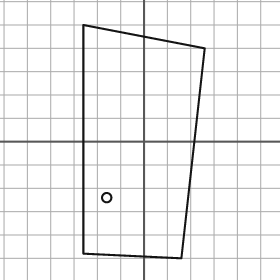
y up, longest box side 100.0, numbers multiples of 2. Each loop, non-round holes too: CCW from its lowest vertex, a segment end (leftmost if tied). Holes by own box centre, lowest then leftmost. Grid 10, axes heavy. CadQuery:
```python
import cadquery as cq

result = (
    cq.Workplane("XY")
    .moveTo(16.0, -50.0)
    .lineTo(26.0, 40.0)
    .lineTo(-26.0, 50.0)
    .lineTo(-26.0, -48.0)
    .close()
    .moveTo(-16.0, -24.0)
    .circle(2.0)
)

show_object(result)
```